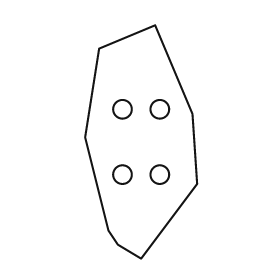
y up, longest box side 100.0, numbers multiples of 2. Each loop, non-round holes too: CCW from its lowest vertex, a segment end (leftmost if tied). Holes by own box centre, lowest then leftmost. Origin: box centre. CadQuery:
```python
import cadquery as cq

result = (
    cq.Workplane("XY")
    .moveTo(0.0, -50.0)
    .lineTo(24.0, -18.0)
    .lineTo(22.0, 12.0)
    .lineTo(6.0, 50.0)
    .lineTo(-18.0, 40.0)
    .lineTo(-24.0, 2.0)
    .lineTo(-14.0, -38.0)
    .lineTo(-10.0, -44.0)
    .close()
    .moveTo(-8.0, -14.0)
    .circle(4.0)
    .moveTo(8.0, -14.0)
    .circle(4.0)
    .moveTo(-8.0, 14.0)
    .circle(4.0)
    .moveTo(8.0, 14.0)
    .circle(4.0)
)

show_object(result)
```